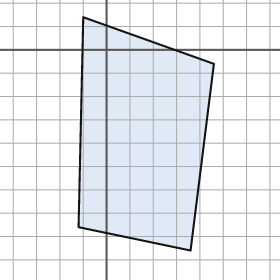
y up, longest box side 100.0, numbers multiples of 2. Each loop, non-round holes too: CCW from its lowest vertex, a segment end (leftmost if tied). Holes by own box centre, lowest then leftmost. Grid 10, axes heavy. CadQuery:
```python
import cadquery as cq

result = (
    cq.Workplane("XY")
    .moveTo(36.0, -86.0)
    .lineTo(46.0, -6.0)
    .lineTo(-10.0, 14.0)
    .lineTo(-12.0, -76.0)
    .close()
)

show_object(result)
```